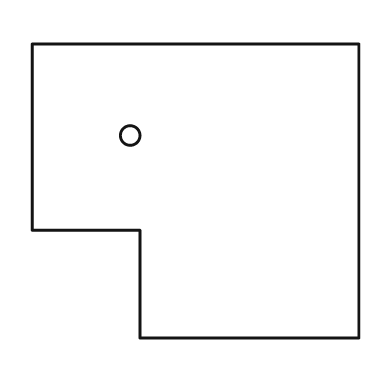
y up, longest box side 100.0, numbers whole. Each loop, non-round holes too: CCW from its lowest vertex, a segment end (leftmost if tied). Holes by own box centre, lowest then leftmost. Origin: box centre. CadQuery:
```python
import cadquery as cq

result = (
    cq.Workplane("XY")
    .moveTo(-17.0, -45.0)
    .lineTo(50.0, -45.0)
    .lineTo(50.0, 45.0)
    .lineTo(-50.0, 45.0)
    .lineTo(-50.0, -12.0)
    .lineTo(-17.0, -12.0)
    .close()
    .moveTo(-20.0, 17.0)
    .circle(3.0)
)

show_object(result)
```